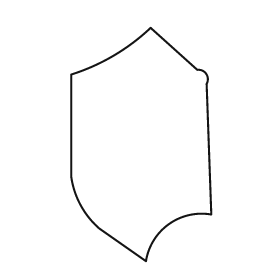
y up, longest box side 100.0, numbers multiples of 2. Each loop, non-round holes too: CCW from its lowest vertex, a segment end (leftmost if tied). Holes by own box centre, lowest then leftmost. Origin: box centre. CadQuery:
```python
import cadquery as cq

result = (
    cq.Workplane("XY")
    .moveTo(2.0, -50.0)
    .threePointArc((12.0, -34.0), (30.0, -30.0))
    .lineTo(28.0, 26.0)
    .threePointArc((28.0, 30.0), (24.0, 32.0))
    .lineTo(4.0, 50.0)
    .threePointArc((-12.0, 38.0), (-30.0, 30.0))
    .lineTo(-30.0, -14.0)
    .threePointArc((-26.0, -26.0), (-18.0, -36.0))
    .close()
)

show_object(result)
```